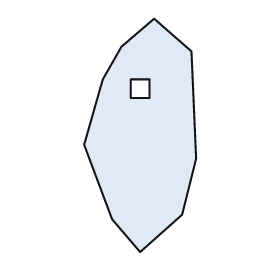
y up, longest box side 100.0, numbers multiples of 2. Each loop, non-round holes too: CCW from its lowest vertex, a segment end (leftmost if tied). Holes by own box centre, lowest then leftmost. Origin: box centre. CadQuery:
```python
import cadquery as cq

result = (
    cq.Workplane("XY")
    .moveTo(0.0, -50.0)
    .lineTo(18.0, -34.0)
    .lineTo(24.0, -10.0)
    .lineTo(22.0, 36.0)
    .lineTo(6.0, 50.0)
    .lineTo(-8.0, 38.0)
    .lineTo(-16.0, 24.0)
    .lineTo(-24.0, -4.0)
    .lineTo(-12.0, -36.0)
    .close()
    .moveTo(-4.0, 16.0)
    .lineTo(4.0, 16.0)
    .lineTo(4.0, 24.0)
    .lineTo(-4.0, 24.0)
    .close()
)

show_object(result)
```